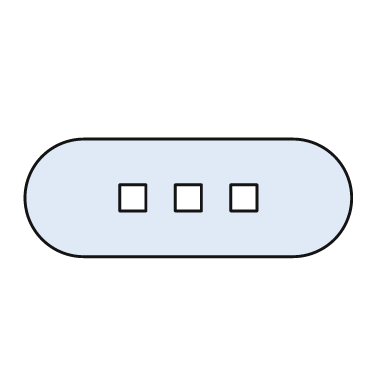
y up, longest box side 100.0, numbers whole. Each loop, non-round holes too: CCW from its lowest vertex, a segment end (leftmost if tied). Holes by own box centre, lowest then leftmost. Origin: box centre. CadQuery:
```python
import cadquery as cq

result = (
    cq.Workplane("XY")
    .moveTo(-32.0, -18.0)
    .lineTo(32.0, -18.0)
    .threePointArc((50.0, 0.0), (32.0, 18.0))
    .lineTo(-32.0, 18.0)
    .threePointArc((-50.0, 0.0), (-32.0, -18.0))
    .close()
    .moveTo(-21.0, -4.0)
    .lineTo(-13.0, -4.0)
    .lineTo(-13.0, 4.0)
    .lineTo(-21.0, 4.0)
    .close()
    .moveTo(-4.0, -4.0)
    .lineTo(4.0, -4.0)
    .lineTo(4.0, 4.0)
    .lineTo(-4.0, 4.0)
    .close()
    .moveTo(13.0, -4.0)
    .lineTo(21.0, -4.0)
    .lineTo(21.0, 4.0)
    .lineTo(13.0, 4.0)
    .close()
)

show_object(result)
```